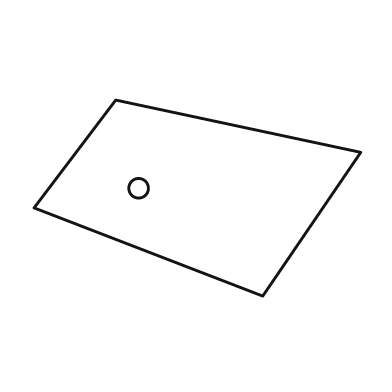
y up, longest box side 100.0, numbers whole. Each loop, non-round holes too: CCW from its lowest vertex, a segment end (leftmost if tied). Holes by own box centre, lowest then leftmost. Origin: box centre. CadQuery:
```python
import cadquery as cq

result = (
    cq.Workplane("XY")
    .moveTo(20.0, -30.0)
    .lineTo(50.0, 14.0)
    .lineTo(-25.0, 30.0)
    .lineTo(-50.0, -3.0)
    .close()
    .moveTo(-18.0, 3.0)
    .circle(3.0)
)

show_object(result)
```